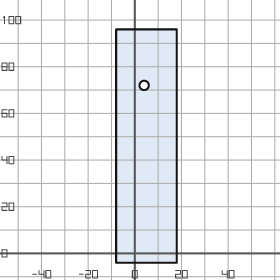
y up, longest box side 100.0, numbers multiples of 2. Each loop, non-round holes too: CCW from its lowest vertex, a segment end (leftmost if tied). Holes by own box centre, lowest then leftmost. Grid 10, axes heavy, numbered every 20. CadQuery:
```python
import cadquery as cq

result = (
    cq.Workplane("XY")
    .moveTo(-8.0, -4.0)
    .lineTo(18.0, -4.0)
    .lineTo(18.0, 96.0)
    .lineTo(-8.0, 96.0)
    .close()
    .moveTo(4.0, 72.0)
    .circle(2.0)
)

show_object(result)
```